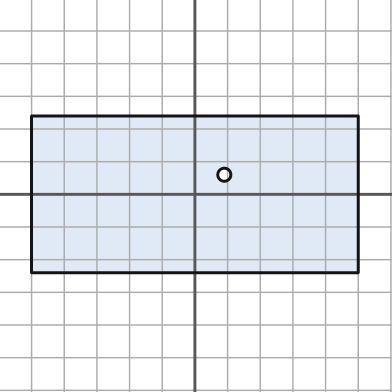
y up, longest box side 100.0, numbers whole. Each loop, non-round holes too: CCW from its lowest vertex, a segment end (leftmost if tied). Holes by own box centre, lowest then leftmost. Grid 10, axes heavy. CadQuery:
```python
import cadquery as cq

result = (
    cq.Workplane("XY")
    .moveTo(-50.0, -24.0)
    .lineTo(50.0, -24.0)
    .lineTo(50.0, 24.0)
    .lineTo(-50.0, 24.0)
    .close()
    .moveTo(9.0, 6.0)
    .circle(2.0)
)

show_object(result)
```